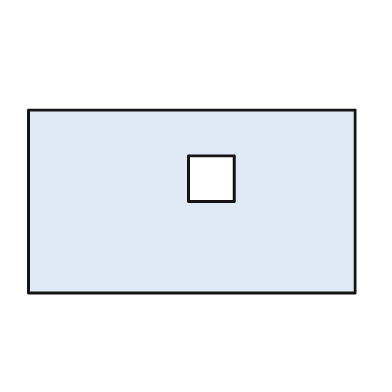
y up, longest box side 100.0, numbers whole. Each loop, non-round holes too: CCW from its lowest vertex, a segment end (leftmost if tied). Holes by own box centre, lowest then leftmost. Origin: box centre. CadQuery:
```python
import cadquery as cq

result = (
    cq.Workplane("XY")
    .moveTo(-50.0, -28.0)
    .lineTo(50.0, -28.0)
    .lineTo(50.0, 28.0)
    .lineTo(-50.0, 28.0)
    .close()
    .moveTo(-1.0, 0.0)
    .lineTo(13.0, 0.0)
    .lineTo(13.0, 14.0)
    .lineTo(-1.0, 14.0)
    .close()
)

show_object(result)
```